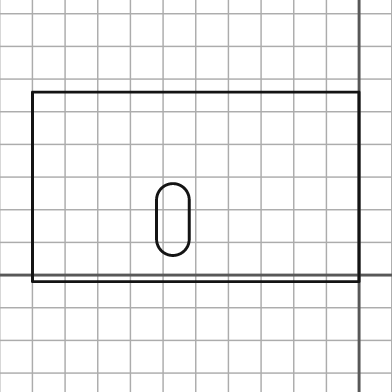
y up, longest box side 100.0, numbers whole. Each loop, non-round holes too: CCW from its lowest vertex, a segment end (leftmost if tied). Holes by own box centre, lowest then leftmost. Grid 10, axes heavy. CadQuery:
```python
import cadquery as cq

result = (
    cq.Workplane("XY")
    .moveTo(-100.0, -2.0)
    .lineTo(0.0, -2.0)
    .lineTo(0.0, 56.0)
    .lineTo(-100.0, 56.0)
    .close()
    .moveTo(-62.0, 11.0)
    .threePointArc((-57.0, 6.0), (-52.0, 11.0))
    .lineTo(-52.0, 23.0)
    .threePointArc((-57.0, 28.0), (-62.0, 23.0))
    .close()
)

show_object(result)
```